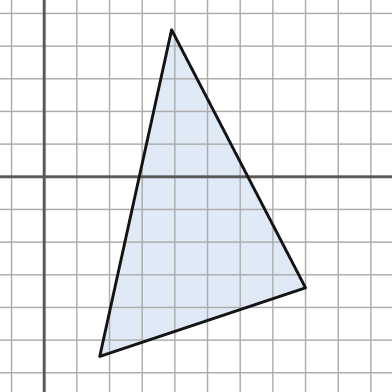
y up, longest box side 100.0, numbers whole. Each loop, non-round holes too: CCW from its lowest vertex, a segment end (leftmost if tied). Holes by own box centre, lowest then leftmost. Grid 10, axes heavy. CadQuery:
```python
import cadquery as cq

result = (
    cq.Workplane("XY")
    .moveTo(17.0, -55.0)
    .lineTo(80.0, -34.0)
    .lineTo(39.0, 45.0)
    .close()
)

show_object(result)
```